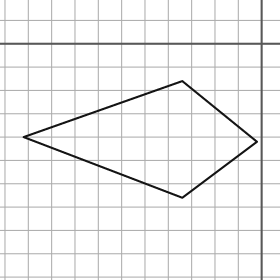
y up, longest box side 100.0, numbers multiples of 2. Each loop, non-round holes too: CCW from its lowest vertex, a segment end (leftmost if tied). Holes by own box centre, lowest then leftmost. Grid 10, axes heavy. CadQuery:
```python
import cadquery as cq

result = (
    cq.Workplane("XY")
    .moveTo(-34.0, -66.0)
    .lineTo(-2.0, -42.0)
    .lineTo(-34.0, -16.0)
    .lineTo(-102.0, -40.0)
    .close()
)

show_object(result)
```